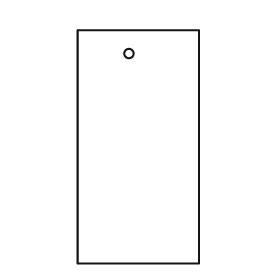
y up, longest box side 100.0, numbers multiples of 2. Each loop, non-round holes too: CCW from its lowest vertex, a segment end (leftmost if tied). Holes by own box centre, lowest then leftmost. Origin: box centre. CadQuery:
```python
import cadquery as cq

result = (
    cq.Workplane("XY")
    .moveTo(-26.0, -50.0)
    .lineTo(26.0, -50.0)
    .lineTo(26.0, 50.0)
    .lineTo(-26.0, 50.0)
    .close()
    .moveTo(-4.0, 40.0)
    .circle(2.0)
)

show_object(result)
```